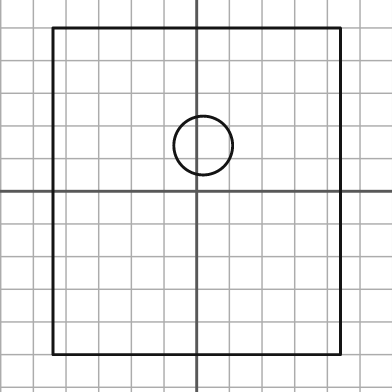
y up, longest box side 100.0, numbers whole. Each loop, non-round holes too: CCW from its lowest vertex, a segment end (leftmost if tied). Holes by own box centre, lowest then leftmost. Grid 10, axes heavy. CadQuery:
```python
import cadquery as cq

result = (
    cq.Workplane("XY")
    .moveTo(-44.0, -50.0)
    .lineTo(44.0, -50.0)
    .lineTo(44.0, 50.0)
    .lineTo(-44.0, 50.0)
    .close()
    .moveTo(2.0, 14.0)
    .circle(9.0)
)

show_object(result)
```